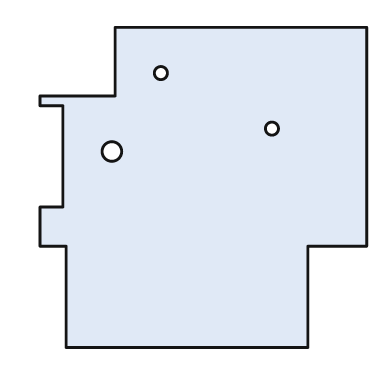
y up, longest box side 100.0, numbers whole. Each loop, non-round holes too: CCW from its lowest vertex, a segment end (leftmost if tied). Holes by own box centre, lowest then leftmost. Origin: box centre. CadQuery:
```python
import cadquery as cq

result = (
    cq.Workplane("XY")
    .moveTo(-42.0, -49.0)
    .lineTo(32.0, -49.0)
    .lineTo(32.0, -18.0)
    .lineTo(50.0, -18.0)
    .lineTo(50.0, 49.0)
    .lineTo(-27.0, 49.0)
    .lineTo(-27.0, 28.0)
    .lineTo(-50.0, 28.0)
    .lineTo(-50.0, 25.0)
    .lineTo(-43.0, 25.0)
    .lineTo(-43.0, -6.0)
    .lineTo(-50.0, -6.0)
    .lineTo(-50.0, -18.0)
    .lineTo(-42.0, -18.0)
    .close()
    .moveTo(-28.0, 11.0)
    .circle(3.0)
    .moveTo(21.0, 18.0)
    .circle(2.0)
    .moveTo(-13.0, 35.0)
    .circle(2.0)
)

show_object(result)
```